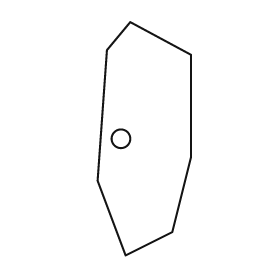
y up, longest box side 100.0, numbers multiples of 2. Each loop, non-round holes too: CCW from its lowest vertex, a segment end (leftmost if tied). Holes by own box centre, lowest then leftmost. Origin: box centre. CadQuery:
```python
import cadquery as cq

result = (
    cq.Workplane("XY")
    .moveTo(-8.0, -50.0)
    .lineTo(12.0, -40.0)
    .lineTo(20.0, -8.0)
    .lineTo(20.0, 36.0)
    .lineTo(-6.0, 50.0)
    .lineTo(-16.0, 38.0)
    .lineTo(-20.0, -18.0)
    .close()
    .moveTo(-10.0, 0.0)
    .circle(4.0)
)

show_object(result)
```